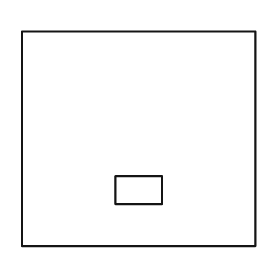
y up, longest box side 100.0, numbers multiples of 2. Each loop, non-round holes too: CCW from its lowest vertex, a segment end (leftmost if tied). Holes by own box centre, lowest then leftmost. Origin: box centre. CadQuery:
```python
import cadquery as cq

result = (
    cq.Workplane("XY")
    .moveTo(-50.0, -46.0)
    .lineTo(50.0, -46.0)
    .lineTo(50.0, 46.0)
    .lineTo(-50.0, 46.0)
    .close()
    .moveTo(-10.0, -28.0)
    .lineTo(10.0, -28.0)
    .lineTo(10.0, -16.0)
    .lineTo(-10.0, -16.0)
    .close()
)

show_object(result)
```